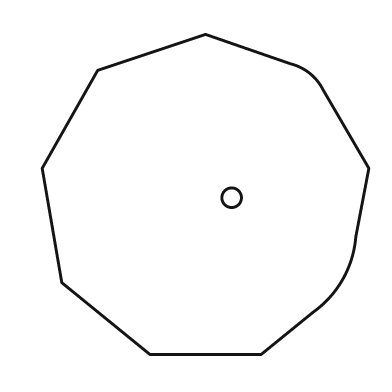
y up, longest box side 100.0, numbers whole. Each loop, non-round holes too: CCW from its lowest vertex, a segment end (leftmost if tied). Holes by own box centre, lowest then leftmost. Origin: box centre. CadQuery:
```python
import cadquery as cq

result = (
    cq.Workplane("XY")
    .moveTo(-17.0, -49.0)
    .lineTo(17.0, -49.0)
    .lineTo(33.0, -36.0)
    .threePointArc((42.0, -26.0), (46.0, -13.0))
    .lineTo(50.0, 8.0)
    .lineTo(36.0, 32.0)
    .threePointArc((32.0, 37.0), (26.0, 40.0))
    .lineTo(0.0, 49.0)
    .lineTo(-33.0, 38.0)
    .lineTo(-50.0, 8.0)
    .lineTo(-44.0, -27.0)
    .close()
    .moveTo(8.0, -1.0)
    .circle(3.0)
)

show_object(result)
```